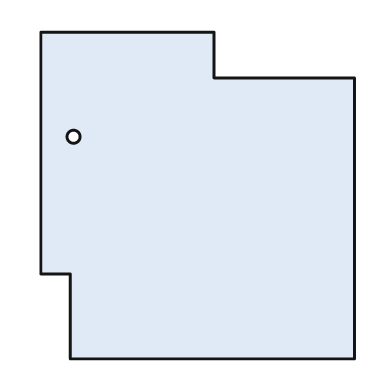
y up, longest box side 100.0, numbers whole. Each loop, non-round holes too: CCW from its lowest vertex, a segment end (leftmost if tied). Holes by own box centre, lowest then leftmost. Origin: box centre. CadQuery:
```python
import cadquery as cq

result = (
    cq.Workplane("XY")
    .moveTo(-39.0, -50.0)
    .lineTo(48.0, -50.0)
    .lineTo(48.0, 36.0)
    .lineTo(5.0, 36.0)
    .lineTo(5.0, 50.0)
    .lineTo(-48.0, 50.0)
    .lineTo(-48.0, -24.0)
    .lineTo(-39.0, -24.0)
    .close()
    .moveTo(-38.0, 18.0)
    .circle(2.0)
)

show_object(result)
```